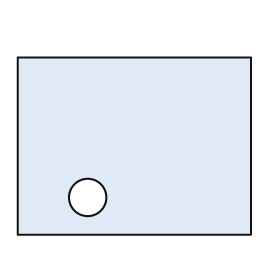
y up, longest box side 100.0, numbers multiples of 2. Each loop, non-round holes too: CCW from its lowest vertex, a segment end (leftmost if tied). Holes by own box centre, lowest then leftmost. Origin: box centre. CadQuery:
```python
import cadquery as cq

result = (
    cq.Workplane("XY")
    .moveTo(-50.0, -38.0)
    .lineTo(50.0, -38.0)
    .lineTo(50.0, 38.0)
    .lineTo(-50.0, 38.0)
    .close()
    .moveTo(-20.0, -22.0)
    .circle(8.0)
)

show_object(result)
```